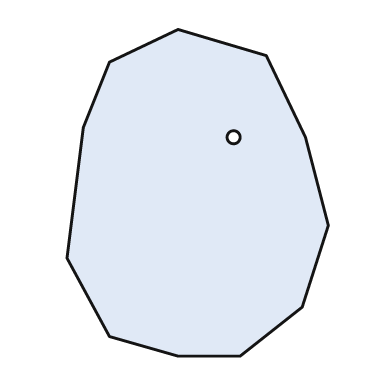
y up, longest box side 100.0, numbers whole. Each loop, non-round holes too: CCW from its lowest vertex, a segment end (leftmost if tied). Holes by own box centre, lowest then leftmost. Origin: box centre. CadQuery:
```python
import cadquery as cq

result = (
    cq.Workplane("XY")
    .moveTo(-6.0, -50.0)
    .lineTo(13.0, -50.0)
    .lineTo(32.0, -35.0)
    .lineTo(40.0, -10.0)
    .lineTo(33.0, 17.0)
    .lineTo(21.0, 42.0)
    .lineTo(-6.0, 50.0)
    .lineTo(-27.0, 40.0)
    .lineTo(-35.0, 20.0)
    .lineTo(-40.0, -20.0)
    .lineTo(-27.0, -44.0)
    .close()
    .moveTo(11.0, 17.0)
    .circle(2.0)
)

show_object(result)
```